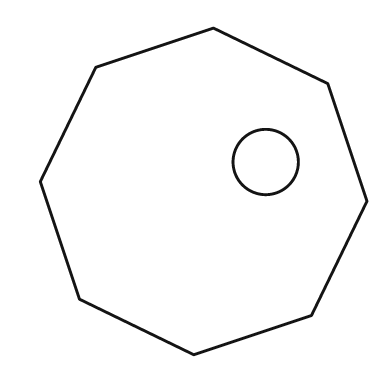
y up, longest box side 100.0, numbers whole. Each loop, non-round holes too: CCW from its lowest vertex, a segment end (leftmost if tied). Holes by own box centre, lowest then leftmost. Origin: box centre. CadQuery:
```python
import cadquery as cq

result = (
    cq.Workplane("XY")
    .moveTo(-3.0, -50.0)
    .lineTo(33.0, -38.0)
    .lineTo(50.0, -3.0)
    .lineTo(38.0, 33.0)
    .lineTo(3.0, 50.0)
    .lineTo(-33.0, 38.0)
    .lineTo(-50.0, 3.0)
    .lineTo(-38.0, -33.0)
    .close()
    .moveTo(19.0, 9.0)
    .circle(10.0)
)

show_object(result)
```